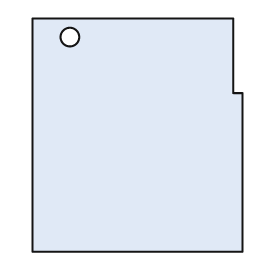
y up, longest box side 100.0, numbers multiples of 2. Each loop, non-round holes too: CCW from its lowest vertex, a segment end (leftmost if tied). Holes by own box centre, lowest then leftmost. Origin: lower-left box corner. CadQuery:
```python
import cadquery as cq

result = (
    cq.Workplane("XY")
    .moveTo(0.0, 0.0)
    .lineTo(90.0, 0.0)
    .lineTo(90.0, 68.0)
    .lineTo(86.0, 68.0)
    .lineTo(86.0, 100.0)
    .lineTo(0.0, 100.0)
    .close()
    .moveTo(16.0, 92.0)
    .circle(4.0)
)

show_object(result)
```